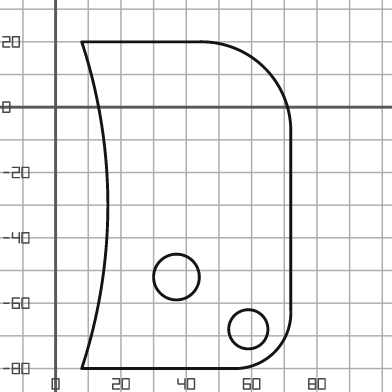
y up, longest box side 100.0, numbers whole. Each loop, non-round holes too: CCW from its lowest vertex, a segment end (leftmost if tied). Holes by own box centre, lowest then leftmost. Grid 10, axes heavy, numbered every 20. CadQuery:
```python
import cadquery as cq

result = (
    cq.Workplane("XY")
    .moveTo(8.0, -80.0)
    .lineTo(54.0, -80.0)
    .threePointArc((67.0, -75.0), (72.0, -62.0))
    .lineTo(72.0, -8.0)
    .threePointArc((64.0, 12.0), (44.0, 20.0))
    .lineTo(8.0, 20.0)
    .threePointArc((16.0, -30.0), (8.0, -80.0))
    .close()
    .moveTo(59.0, -68.0)
    .circle(6.0)
    .moveTo(37.0, -52.0)
    .circle(7.0)
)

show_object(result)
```